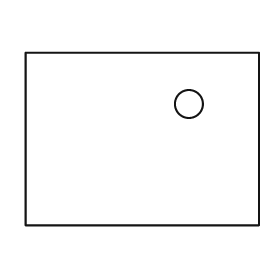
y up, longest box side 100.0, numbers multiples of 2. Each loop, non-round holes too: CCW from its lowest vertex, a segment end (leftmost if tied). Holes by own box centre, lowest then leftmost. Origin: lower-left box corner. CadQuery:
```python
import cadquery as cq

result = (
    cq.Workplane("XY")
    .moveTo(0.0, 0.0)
    .lineTo(100.0, 0.0)
    .lineTo(100.0, 74.0)
    .lineTo(0.0, 74.0)
    .close()
    .moveTo(70.0, 52.0)
    .circle(6.0)
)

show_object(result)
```